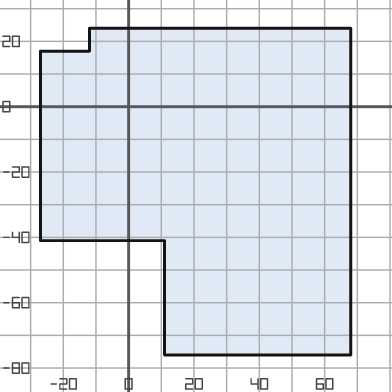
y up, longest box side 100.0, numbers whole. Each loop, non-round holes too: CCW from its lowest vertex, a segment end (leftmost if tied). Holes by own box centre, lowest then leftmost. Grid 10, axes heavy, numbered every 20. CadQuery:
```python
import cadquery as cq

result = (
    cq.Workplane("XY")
    .moveTo(11.0, -76.0)
    .lineTo(68.0, -76.0)
    .lineTo(68.0, 24.0)
    .lineTo(-12.0, 24.0)
    .lineTo(-12.0, 17.0)
    .lineTo(-27.0, 17.0)
    .lineTo(-27.0, -41.0)
    .lineTo(11.0, -41.0)
    .close()
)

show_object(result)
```